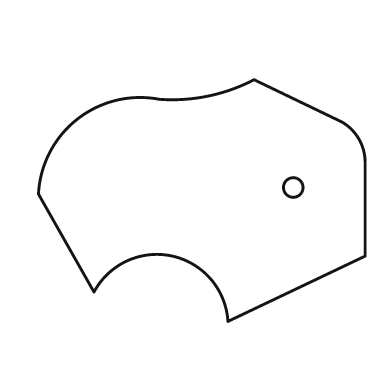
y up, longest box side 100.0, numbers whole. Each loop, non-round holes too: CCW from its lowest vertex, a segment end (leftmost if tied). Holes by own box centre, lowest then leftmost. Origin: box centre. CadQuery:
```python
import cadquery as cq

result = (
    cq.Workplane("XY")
    .moveTo(8.0, -37.0)
    .lineTo(50.0, -17.0)
    .lineTo(50.0, 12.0)
    .threePointArc((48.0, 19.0), (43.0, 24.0))
    .lineTo(16.0, 37.0)
    .threePointArc((2.0, 32.0), (-13.0, 31.0))
    .threePointArc((-38.0, 25.0), (-50.0, 2.0))
    .lineTo(-33.0, -28.0)
    .threePointArc((-9.0, -17.0), (8.0, -37.0))
    .close()
    .moveTo(28.0, 4.0)
    .circle(3.0)
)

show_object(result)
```